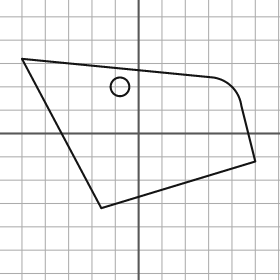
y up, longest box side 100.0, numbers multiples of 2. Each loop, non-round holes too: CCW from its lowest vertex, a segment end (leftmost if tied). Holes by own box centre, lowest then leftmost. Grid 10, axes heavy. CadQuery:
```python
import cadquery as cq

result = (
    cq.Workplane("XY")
    .moveTo(-16.0, -32.0)
    .lineTo(50.0, -12.0)
    .lineTo(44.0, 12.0)
    .threePointArc((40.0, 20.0), (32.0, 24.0))
    .lineTo(-50.0, 32.0)
    .close()
    .moveTo(-8.0, 20.0)
    .circle(4.0)
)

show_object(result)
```